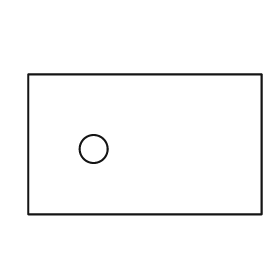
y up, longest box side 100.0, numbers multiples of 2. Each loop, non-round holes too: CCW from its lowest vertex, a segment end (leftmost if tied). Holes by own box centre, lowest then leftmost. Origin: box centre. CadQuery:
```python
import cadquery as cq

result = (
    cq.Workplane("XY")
    .moveTo(-50.0, -30.0)
    .lineTo(50.0, -30.0)
    .lineTo(50.0, 30.0)
    .lineTo(-50.0, 30.0)
    .close()
    .moveTo(-22.0, -2.0)
    .circle(6.0)
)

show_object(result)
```